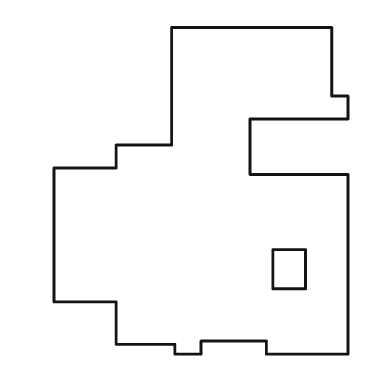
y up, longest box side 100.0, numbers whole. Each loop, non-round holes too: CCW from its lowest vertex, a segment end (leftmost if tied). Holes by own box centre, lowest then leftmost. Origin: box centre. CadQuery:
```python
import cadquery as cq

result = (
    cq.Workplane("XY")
    .moveTo(-8.0, -50.0)
    .lineTo(0.0, -50.0)
    .lineTo(0.0, -46.0)
    .lineTo(20.0, -46.0)
    .lineTo(20.0, -50.0)
    .lineTo(45.0, -50.0)
    .lineTo(45.0, 5.0)
    .lineTo(15.0, 5.0)
    .lineTo(15.0, 22.0)
    .lineTo(45.0, 22.0)
    .lineTo(45.0, 29.0)
    .lineTo(40.0, 29.0)
    .lineTo(40.0, 50.0)
    .lineTo(-9.0, 50.0)
    .lineTo(-9.0, 14.0)
    .lineTo(-26.0, 14.0)
    .lineTo(-26.0, 7.0)
    .lineTo(-45.0, 7.0)
    .lineTo(-45.0, -34.0)
    .lineTo(-26.0, -34.0)
    .lineTo(-26.0, -47.0)
    .lineTo(-8.0, -47.0)
    .close()
    .moveTo(22.0, -30.0)
    .lineTo(32.0, -30.0)
    .lineTo(32.0, -18.0)
    .lineTo(22.0, -18.0)
    .close()
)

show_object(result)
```